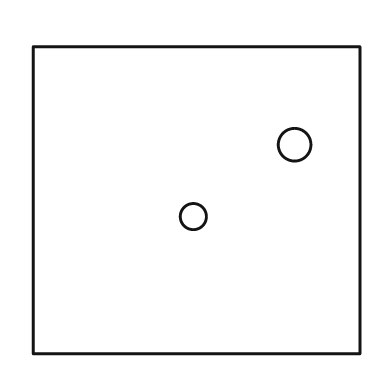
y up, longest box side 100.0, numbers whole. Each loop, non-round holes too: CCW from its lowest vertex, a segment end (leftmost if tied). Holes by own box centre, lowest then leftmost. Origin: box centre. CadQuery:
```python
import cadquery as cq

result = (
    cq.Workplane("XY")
    .moveTo(-50.0, -47.0)
    .lineTo(50.0, -47.0)
    .lineTo(50.0, 47.0)
    .lineTo(-50.0, 47.0)
    .close()
    .moveTo(-1.0, -5.0)
    .circle(4.0)
    .moveTo(30.0, 17.0)
    .circle(5.0)
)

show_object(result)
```